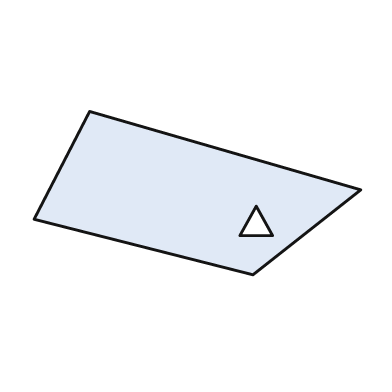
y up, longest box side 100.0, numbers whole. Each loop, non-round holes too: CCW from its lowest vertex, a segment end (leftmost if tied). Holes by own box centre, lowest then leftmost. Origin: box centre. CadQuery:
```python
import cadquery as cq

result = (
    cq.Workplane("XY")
    .moveTo(17.0, -25.0)
    .lineTo(50.0, 1.0)
    .lineTo(-33.0, 25.0)
    .lineTo(-50.0, -8.0)
    .close()
    .moveTo(13.0, -13.0)
    .lineTo(23.0, -13.0)
    .lineTo(18.0, -4.0)
    .close()
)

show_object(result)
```